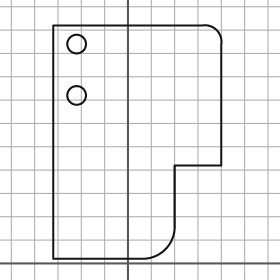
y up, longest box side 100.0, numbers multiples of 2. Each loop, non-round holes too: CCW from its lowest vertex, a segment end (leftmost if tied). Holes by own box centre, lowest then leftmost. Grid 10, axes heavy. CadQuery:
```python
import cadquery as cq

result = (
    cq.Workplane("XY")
    .moveTo(-32.0, 2.0)
    .lineTo(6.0, 2.0)
    .threePointArc((16.0, 6.0), (20.0, 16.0))
    .lineTo(20.0, 42.0)
    .lineTo(40.0, 42.0)
    .lineTo(40.0, 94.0)
    .threePointArc((38.0, 100.0), (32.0, 102.0))
    .lineTo(-32.0, 102.0)
    .close()
    .moveTo(-22.0, 72.0)
    .circle(4.0)
    .moveTo(-22.0, 94.0)
    .circle(4.0)
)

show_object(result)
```